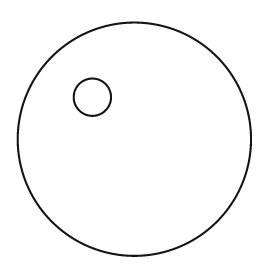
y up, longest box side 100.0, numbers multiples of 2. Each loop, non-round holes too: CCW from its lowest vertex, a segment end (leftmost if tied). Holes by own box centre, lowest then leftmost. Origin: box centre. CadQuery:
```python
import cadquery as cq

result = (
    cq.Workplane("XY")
    .moveTo(0.0, 0.0)
    .circle(50.0)
    .moveTo(-18.0, 18.0)
    .circle(8.0)
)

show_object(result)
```